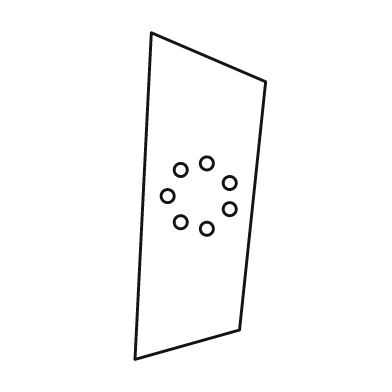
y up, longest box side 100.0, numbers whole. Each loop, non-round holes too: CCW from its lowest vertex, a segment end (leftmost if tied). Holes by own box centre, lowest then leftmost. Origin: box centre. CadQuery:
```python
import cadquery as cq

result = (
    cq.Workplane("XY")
    .moveTo(-20.0, -50.0)
    .lineTo(12.0, -41.0)
    .lineTo(20.0, 35.0)
    .lineTo(-15.0, 50.0)
    .close()
    .moveTo(2.0, -10.0)
    .circle(2.0)
    .moveTo(-6.0, -8.0)
    .circle(2.0)
    .moveTo(9.0, -4.0)
    .circle(2.0)
    .moveTo(-10.0, 0.0)
    .circle(2.0)
    .moveTo(9.0, 4.0)
    .circle(2.0)
    .moveTo(-6.0, 8.0)
    .circle(2.0)
    .moveTo(2.0, 10.0)
    .circle(2.0)
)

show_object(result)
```